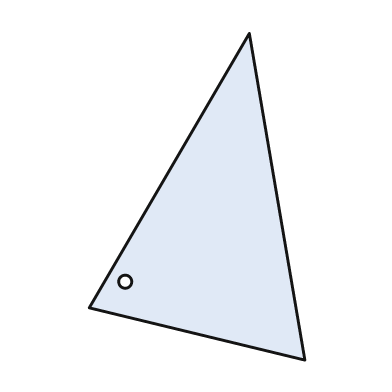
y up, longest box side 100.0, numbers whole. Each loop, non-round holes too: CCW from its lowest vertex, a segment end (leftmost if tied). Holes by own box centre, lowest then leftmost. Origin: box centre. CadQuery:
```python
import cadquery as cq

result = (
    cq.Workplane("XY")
    .moveTo(33.0, -50.0)
    .lineTo(16.0, 50.0)
    .lineTo(-33.0, -34.0)
    .close()
    .moveTo(-22.0, -26.0)
    .circle(2.0)
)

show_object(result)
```